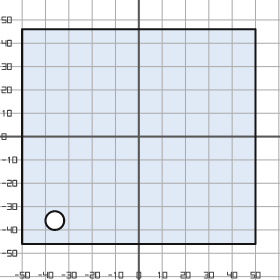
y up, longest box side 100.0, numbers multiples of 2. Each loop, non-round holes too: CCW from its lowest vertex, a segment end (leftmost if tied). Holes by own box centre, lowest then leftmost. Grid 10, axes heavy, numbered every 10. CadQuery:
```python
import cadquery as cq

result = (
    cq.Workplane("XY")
    .moveTo(-50.0, -46.0)
    .lineTo(50.0, -46.0)
    .lineTo(50.0, 46.0)
    .lineTo(-50.0, 46.0)
    .close()
    .moveTo(-36.0, -36.0)
    .circle(4.0)
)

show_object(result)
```